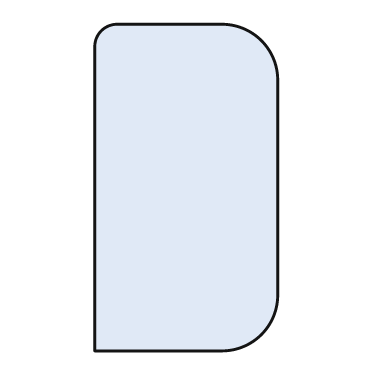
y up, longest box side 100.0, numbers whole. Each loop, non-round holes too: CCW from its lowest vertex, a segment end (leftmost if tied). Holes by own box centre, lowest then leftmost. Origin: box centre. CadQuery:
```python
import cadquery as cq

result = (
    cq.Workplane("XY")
    .moveTo(-28.0, -50.0)
    .lineTo(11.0, -50.0)
    .threePointArc((23.0, -45.0), (28.0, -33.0))
    .lineTo(28.0, 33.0)
    .threePointArc((23.0, 45.0), (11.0, 50.0))
    .lineTo(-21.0, 50.0)
    .threePointArc((-26.0, 48.0), (-28.0, 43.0))
    .close()
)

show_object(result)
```